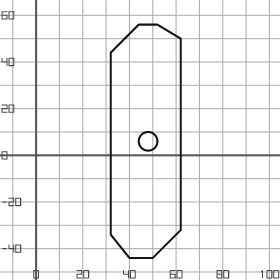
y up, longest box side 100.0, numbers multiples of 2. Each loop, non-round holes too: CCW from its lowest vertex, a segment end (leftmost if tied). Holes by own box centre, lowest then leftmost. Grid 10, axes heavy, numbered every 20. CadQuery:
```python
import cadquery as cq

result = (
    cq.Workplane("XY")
    .moveTo(40.0, -44.0)
    .lineTo(50.0, -44.0)
    .lineTo(62.0, -32.0)
    .lineTo(62.0, 50.0)
    .lineTo(52.0, 56.0)
    .lineTo(44.0, 56.0)
    .lineTo(32.0, 44.0)
    .lineTo(32.0, -34.0)
    .close()
    .moveTo(48.0, 6.0)
    .circle(4.0)
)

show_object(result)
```